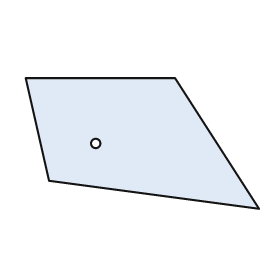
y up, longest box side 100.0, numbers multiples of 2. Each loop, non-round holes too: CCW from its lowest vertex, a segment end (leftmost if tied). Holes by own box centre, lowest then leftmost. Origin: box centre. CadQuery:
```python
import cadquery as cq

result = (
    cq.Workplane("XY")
    .moveTo(50.0, -28.0)
    .lineTo(14.0, 28.0)
    .lineTo(-50.0, 28.0)
    .lineTo(-40.0, -16.0)
    .close()
    .moveTo(-20.0, 0.0)
    .circle(2.0)
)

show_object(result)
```